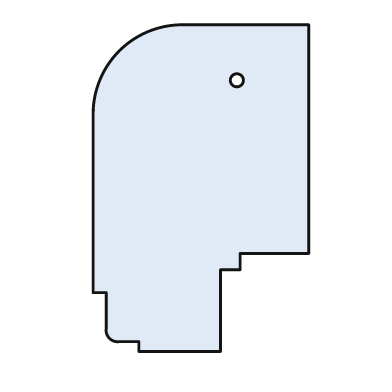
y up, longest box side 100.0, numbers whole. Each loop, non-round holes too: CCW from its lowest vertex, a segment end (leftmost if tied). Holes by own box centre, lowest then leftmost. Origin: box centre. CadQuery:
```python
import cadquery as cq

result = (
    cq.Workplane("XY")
    .moveTo(-19.0, -50.0)
    .lineTo(6.0, -50.0)
    .lineTo(6.0, -25.0)
    .lineTo(12.0, -25.0)
    .lineTo(12.0, -20.0)
    .lineTo(33.0, -20.0)
    .lineTo(33.0, 50.0)
    .lineTo(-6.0, 50.0)
    .threePointArc((-25.0, 42.0), (-33.0, 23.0))
    .lineTo(-33.0, -32.0)
    .lineTo(-29.0, -32.0)
    .lineTo(-29.0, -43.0)
    .threePointArc((-28.0, -46.0), (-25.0, -47.0))
    .lineTo(-19.0, -47.0)
    .close()
    .moveTo(11.0, 33.0)
    .circle(2.0)
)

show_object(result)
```